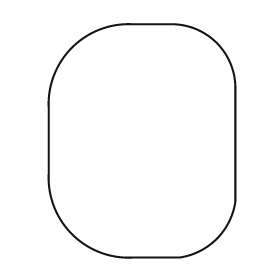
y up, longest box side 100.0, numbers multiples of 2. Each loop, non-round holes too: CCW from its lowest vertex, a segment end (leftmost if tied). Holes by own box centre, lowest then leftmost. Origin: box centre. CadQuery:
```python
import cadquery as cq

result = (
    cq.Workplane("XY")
    .moveTo(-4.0, -50.0)
    .lineTo(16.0, -50.0)
    .threePointArc((32.0, -42.0), (40.0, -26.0))
    .lineTo(40.0, 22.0)
    .threePointArc((32.0, 42.0), (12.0, 50.0))
    .lineTo(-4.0, 50.0)
    .threePointArc((-30.0, 40.0), (-40.0, 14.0))
    .lineTo(-40.0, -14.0)
    .threePointArc((-30.0, -40.0), (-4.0, -50.0))
    .close()
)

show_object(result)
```